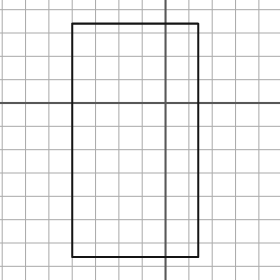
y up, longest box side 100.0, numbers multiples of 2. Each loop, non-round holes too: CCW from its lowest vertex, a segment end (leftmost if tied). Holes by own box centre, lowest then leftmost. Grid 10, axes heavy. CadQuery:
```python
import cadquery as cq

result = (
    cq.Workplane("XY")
    .moveTo(-40.0, -66.0)
    .lineTo(14.0, -66.0)
    .lineTo(14.0, 34.0)
    .lineTo(-40.0, 34.0)
    .close()
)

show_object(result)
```